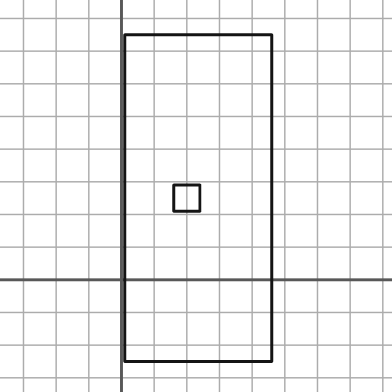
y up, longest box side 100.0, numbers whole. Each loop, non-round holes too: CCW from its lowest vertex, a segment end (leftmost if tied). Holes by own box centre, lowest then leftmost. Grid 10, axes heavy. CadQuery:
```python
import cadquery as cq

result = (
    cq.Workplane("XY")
    .moveTo(1.0, -25.0)
    .lineTo(46.0, -25.0)
    .lineTo(46.0, 75.0)
    .lineTo(1.0, 75.0)
    .close()
    .moveTo(16.0, 21.0)
    .lineTo(24.0, 21.0)
    .lineTo(24.0, 29.0)
    .lineTo(16.0, 29.0)
    .close()
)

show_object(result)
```